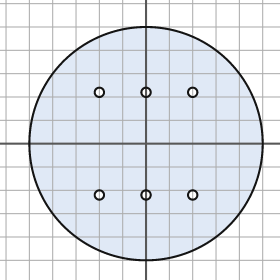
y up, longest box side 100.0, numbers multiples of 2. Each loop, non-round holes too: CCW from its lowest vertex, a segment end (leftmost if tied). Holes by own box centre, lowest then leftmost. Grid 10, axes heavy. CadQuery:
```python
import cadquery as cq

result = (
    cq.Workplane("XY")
    .moveTo(0.0, 0.0)
    .circle(50.0)
    .moveTo(-20.0, -22.0)
    .circle(2.0)
    .moveTo(0.0, -22.0)
    .circle(2.0)
    .moveTo(20.0, -22.0)
    .circle(2.0)
    .moveTo(-20.0, 22.0)
    .circle(2.0)
    .moveTo(0.0, 22.0)
    .circle(2.0)
    .moveTo(20.0, 22.0)
    .circle(2.0)
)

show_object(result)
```